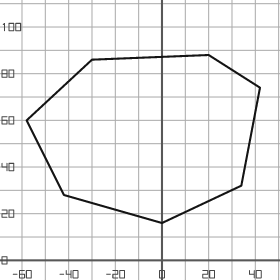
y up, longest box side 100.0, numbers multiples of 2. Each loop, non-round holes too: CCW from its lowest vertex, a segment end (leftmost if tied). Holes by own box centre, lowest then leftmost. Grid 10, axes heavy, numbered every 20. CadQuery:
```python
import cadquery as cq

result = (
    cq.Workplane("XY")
    .moveTo(0.0, 16.0)
    .lineTo(34.0, 32.0)
    .lineTo(42.0, 74.0)
    .lineTo(20.0, 88.0)
    .lineTo(-30.0, 86.0)
    .lineTo(-58.0, 60.0)
    .lineTo(-42.0, 28.0)
    .close()
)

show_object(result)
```